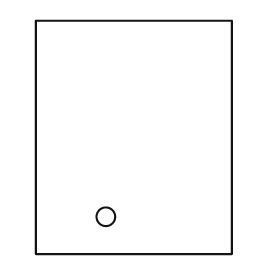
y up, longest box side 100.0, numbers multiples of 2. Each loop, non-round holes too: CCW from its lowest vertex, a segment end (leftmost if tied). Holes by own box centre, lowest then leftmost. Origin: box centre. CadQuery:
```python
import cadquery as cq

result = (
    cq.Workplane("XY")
    .moveTo(-42.0, -50.0)
    .lineTo(42.0, -50.0)
    .lineTo(42.0, 50.0)
    .lineTo(-42.0, 50.0)
    .close()
    .moveTo(-12.0, -34.0)
    .circle(4.0)
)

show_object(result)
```